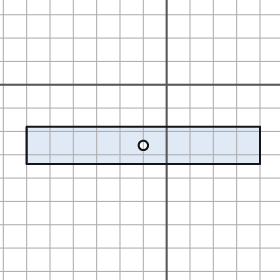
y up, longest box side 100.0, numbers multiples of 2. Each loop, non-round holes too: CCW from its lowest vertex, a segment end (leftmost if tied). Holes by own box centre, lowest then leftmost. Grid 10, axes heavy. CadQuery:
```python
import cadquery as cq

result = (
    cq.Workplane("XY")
    .moveTo(-60.0, -34.0)
    .lineTo(40.0, -34.0)
    .lineTo(40.0, -18.0)
    .lineTo(-60.0, -18.0)
    .close()
    .moveTo(-10.0, -26.0)
    .circle(2.0)
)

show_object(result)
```